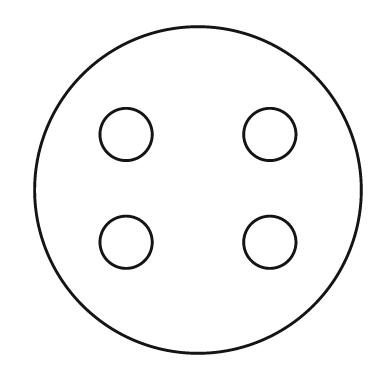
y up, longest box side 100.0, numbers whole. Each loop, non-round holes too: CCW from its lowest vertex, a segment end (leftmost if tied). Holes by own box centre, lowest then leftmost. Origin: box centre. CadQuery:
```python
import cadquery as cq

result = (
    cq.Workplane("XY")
    .moveTo(0.0, 0.0)
    .circle(50.0)
    .moveTo(-22.0, -16.0)
    .circle(8.0)
    .moveTo(22.0, -16.0)
    .circle(8.0)
    .moveTo(-22.0, 17.0)
    .circle(8.0)
    .moveTo(22.0, 17.0)
    .circle(8.0)
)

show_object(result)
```